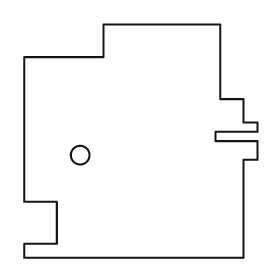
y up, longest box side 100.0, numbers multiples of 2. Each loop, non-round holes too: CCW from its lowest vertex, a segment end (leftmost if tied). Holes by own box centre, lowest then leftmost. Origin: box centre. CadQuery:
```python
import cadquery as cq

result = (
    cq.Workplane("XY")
    .moveTo(-50.0, -50.0)
    .lineTo(44.0, -50.0)
    .lineTo(44.0, -8.0)
    .lineTo(50.0, -8.0)
    .lineTo(50.0, 0.0)
    .lineTo(32.0, 0.0)
    .lineTo(32.0, 4.0)
    .lineTo(50.0, 4.0)
    .lineTo(50.0, 8.0)
    .lineTo(44.0, 8.0)
    .lineTo(44.0, 18.0)
    .lineTo(34.0, 18.0)
    .lineTo(34.0, 50.0)
    .lineTo(-16.0, 50.0)
    .lineTo(-16.0, 36.0)
    .lineTo(-50.0, 36.0)
    .lineTo(-50.0, -26.0)
    .lineTo(-36.0, -26.0)
    .lineTo(-36.0, -44.0)
    .lineTo(-50.0, -44.0)
    .close()
    .moveTo(-26.0, -6.0)
    .circle(4.0)
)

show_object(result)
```